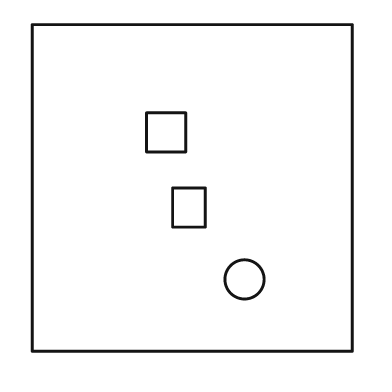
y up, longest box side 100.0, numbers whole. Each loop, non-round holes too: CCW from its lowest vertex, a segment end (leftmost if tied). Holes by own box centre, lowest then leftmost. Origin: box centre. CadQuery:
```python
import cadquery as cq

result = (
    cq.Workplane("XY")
    .moveTo(-49.0, -50.0)
    .lineTo(49.0, -50.0)
    .lineTo(49.0, 50.0)
    .lineTo(-49.0, 50.0)
    .close()
    .moveTo(16.0, -28.0)
    .circle(6.0)
    .moveTo(-6.0, -12.0)
    .lineTo(4.0, -12.0)
    .lineTo(4.0, 0.0)
    .lineTo(-6.0, 0.0)
    .close()
    .moveTo(-14.0, 11.0)
    .lineTo(-2.0, 11.0)
    .lineTo(-2.0, 23.0)
    .lineTo(-14.0, 23.0)
    .close()
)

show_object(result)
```